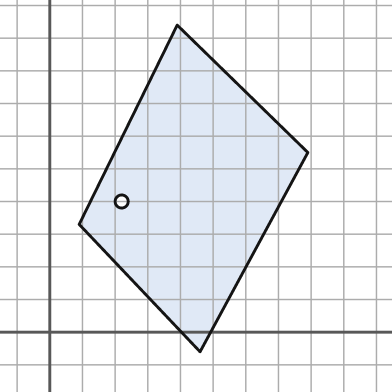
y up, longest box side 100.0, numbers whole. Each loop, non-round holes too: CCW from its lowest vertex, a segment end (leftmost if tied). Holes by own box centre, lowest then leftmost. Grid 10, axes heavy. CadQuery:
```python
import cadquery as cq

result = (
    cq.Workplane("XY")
    .moveTo(46.0, -6.0)
    .lineTo(79.0, 55.0)
    .lineTo(39.0, 94.0)
    .lineTo(9.0, 33.0)
    .close()
    .moveTo(22.0, 40.0)
    .circle(2.0)
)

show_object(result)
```